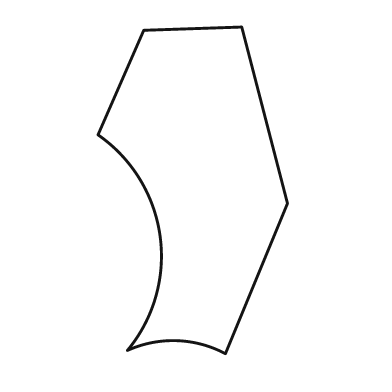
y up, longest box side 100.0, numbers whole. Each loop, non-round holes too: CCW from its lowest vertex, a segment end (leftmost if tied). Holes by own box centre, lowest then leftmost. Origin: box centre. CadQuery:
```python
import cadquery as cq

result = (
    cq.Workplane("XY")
    .moveTo(10.0, -50.0)
    .lineTo(29.0, -4.0)
    .lineTo(15.0, 50.0)
    .lineTo(-15.0, 49.0)
    .lineTo(-29.0, 17.0)
    .threePointArc((-10.0, -14.0), (-20.0, -49.0))
    .threePointArc((-5.0, -46.0), (10.0, -50.0))
    .close()
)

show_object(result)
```